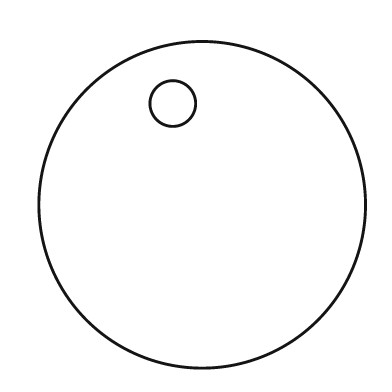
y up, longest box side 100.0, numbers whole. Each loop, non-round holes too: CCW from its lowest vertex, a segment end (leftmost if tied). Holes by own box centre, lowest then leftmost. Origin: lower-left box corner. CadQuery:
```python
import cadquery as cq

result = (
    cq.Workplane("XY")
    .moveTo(50.0, 50.0)
    .circle(50.0)
    .moveTo(41.0, 81.0)
    .circle(7.0)
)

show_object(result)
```